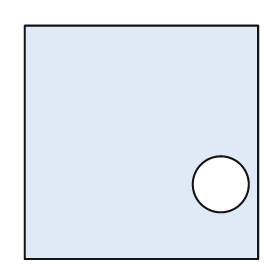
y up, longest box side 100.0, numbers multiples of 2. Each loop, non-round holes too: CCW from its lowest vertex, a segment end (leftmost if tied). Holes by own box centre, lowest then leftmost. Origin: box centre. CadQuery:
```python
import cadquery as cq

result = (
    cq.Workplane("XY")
    .moveTo(-50.0, -50.0)
    .lineTo(50.0, -50.0)
    .lineTo(50.0, 50.0)
    .lineTo(-50.0, 50.0)
    .close()
    .moveTo(34.0, -18.0)
    .circle(12.0)
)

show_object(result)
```